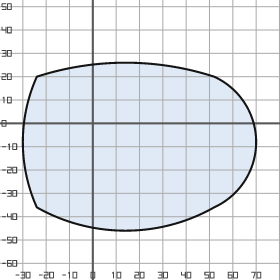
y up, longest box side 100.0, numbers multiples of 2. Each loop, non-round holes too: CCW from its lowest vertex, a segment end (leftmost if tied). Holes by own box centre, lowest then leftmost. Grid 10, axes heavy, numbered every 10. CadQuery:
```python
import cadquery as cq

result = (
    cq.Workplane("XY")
    .moveTo(-24.0, -36.0)
    .threePointArc((14.0, -46.0), (52.0, -36.0))
    .threePointArc((70.0, -8.0), (52.0, 20.0))
    .threePointArc((14.0, 26.0), (-24.0, 20.0))
    .threePointArc((-30.0, -8.0), (-24.0, -36.0))
    .close()
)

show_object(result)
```